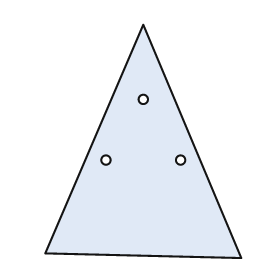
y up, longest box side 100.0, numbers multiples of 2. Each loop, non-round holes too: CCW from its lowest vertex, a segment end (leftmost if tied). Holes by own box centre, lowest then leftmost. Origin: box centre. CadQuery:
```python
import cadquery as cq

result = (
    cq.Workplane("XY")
    .moveTo(42.0, -50.0)
    .lineTo(0.0, 50.0)
    .lineTo(-42.0, -48.0)
    .close()
    .moveTo(-16.0, -8.0)
    .circle(2.0)
    .moveTo(16.0, -8.0)
    .circle(2.0)
    .moveTo(0.0, 18.0)
    .circle(2.0)
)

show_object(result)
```